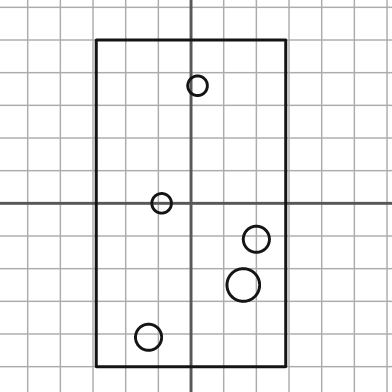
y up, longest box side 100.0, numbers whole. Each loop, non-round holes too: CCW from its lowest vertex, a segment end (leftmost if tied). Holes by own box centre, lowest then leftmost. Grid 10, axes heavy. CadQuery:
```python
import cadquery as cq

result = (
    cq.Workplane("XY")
    .moveTo(-29.0, -50.0)
    .lineTo(29.0, -50.0)
    .lineTo(29.0, 50.0)
    .lineTo(-29.0, 50.0)
    .close()
    .moveTo(-13.0, -41.0)
    .circle(4.0)
    .moveTo(16.0, -25.0)
    .circle(5.0)
    .moveTo(20.0, -11.0)
    .circle(4.0)
    .moveTo(-9.0, 0.0)
    .circle(3.0)
    .moveTo(2.0, 36.0)
    .circle(3.0)
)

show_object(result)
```